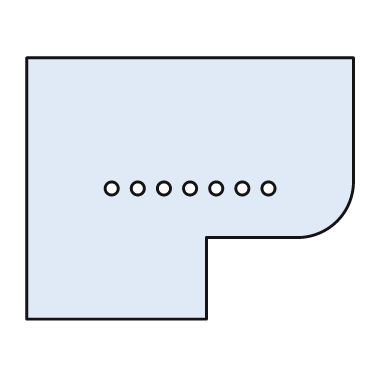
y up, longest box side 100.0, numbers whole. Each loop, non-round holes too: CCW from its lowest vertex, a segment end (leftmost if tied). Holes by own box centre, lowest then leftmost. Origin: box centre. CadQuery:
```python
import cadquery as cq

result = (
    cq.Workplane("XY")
    .moveTo(-50.0, -40.0)
    .lineTo(5.0, -40.0)
    .lineTo(5.0, -15.0)
    .lineTo(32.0, -15.0)
    .threePointArc((45.0, -10.0), (50.0, 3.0))
    .lineTo(50.0, 40.0)
    .lineTo(-50.0, 40.0)
    .close()
    .moveTo(-24.0, 0.0)
    .circle(2.0)
    .moveTo(-16.0, 0.0)
    .circle(2.0)
    .moveTo(-8.0, 0.0)
    .circle(2.0)
    .moveTo(0.0, 0.0)
    .circle(2.0)
    .moveTo(8.0, 0.0)
    .circle(2.0)
    .moveTo(16.0, 0.0)
    .circle(2.0)
    .moveTo(24.0, 0.0)
    .circle(2.0)
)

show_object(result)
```